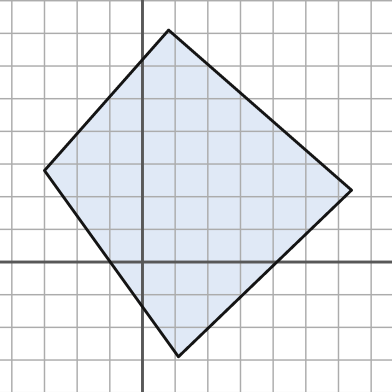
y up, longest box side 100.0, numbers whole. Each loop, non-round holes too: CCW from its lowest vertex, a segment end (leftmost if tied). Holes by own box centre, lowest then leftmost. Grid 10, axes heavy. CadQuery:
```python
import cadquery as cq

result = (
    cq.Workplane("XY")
    .moveTo(11.0, -29.0)
    .lineTo(64.0, 22.0)
    .lineTo(8.0, 71.0)
    .lineTo(-30.0, 28.0)
    .close()
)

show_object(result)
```